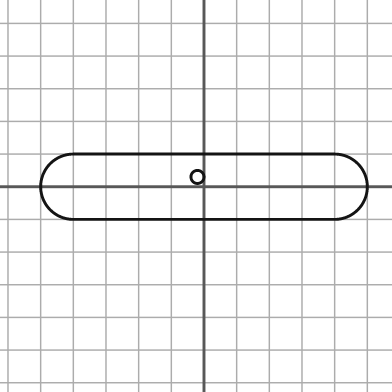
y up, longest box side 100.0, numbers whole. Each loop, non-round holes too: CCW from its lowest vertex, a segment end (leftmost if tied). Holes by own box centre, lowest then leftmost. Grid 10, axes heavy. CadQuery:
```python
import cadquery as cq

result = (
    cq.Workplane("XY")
    .moveTo(-40.0, -10.0)
    .lineTo(40.0, -10.0)
    .threePointArc((50.0, 0.0), (40.0, 10.0))
    .lineTo(-40.0, 10.0)
    .threePointArc((-50.0, 0.0), (-40.0, -10.0))
    .close()
    .moveTo(-2.0, 3.0)
    .circle(2.0)
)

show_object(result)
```